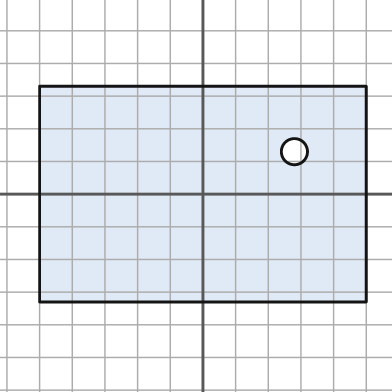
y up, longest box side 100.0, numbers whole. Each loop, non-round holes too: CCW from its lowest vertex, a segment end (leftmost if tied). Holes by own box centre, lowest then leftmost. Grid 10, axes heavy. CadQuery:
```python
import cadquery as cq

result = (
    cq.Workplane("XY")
    .moveTo(-50.0, -33.0)
    .lineTo(50.0, -33.0)
    .lineTo(50.0, 33.0)
    .lineTo(-50.0, 33.0)
    .close()
    .moveTo(28.0, 13.0)
    .circle(4.0)
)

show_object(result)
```